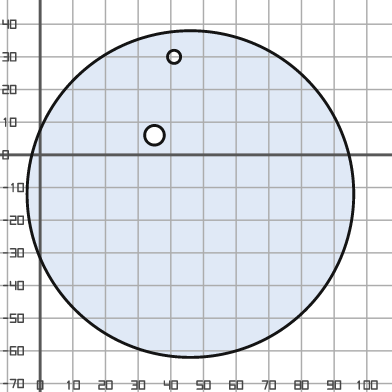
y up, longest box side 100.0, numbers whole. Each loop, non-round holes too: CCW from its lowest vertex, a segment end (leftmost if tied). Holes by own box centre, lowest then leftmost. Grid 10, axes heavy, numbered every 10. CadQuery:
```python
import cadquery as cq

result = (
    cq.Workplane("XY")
    .moveTo(46.0, -12.0)
    .circle(50.0)
    .moveTo(35.0, 6.0)
    .circle(3.0)
    .moveTo(41.0, 30.0)
    .circle(2.0)
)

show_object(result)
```